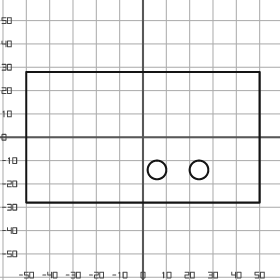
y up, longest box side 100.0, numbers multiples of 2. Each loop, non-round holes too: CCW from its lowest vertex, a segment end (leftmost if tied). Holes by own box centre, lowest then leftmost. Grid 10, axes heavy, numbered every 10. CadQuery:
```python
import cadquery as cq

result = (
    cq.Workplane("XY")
    .moveTo(-50.0, -28.0)
    .lineTo(50.0, -28.0)
    .lineTo(50.0, 28.0)
    .lineTo(-50.0, 28.0)
    .close()
    .moveTo(6.0, -14.0)
    .circle(4.0)
    .moveTo(24.0, -14.0)
    .circle(4.0)
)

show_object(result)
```